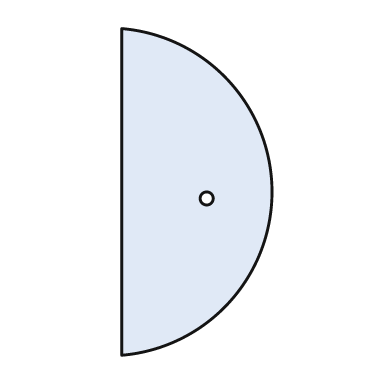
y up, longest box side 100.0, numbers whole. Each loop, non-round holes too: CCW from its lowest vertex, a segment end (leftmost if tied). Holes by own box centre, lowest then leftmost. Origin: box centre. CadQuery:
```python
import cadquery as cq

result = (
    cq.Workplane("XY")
    .moveTo(-23.0, -50.0)
    .threePointArc((23.0, 0.0), (-23.0, 50.0))
    .close()
    .moveTo(3.0, -2.0)
    .circle(2.0)
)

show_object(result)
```